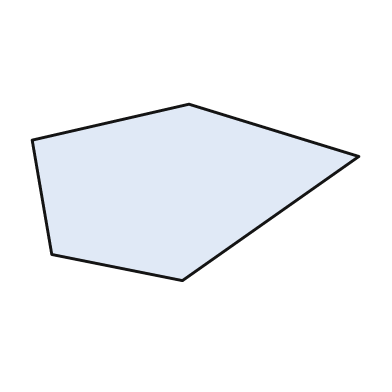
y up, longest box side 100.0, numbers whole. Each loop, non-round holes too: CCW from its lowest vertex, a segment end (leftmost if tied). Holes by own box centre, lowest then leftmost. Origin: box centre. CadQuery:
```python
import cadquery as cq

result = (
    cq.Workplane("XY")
    .moveTo(-4.0, -27.0)
    .lineTo(50.0, 11.0)
    .lineTo(-2.0, 27.0)
    .lineTo(-50.0, 16.0)
    .lineTo(-44.0, -19.0)
    .close()
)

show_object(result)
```